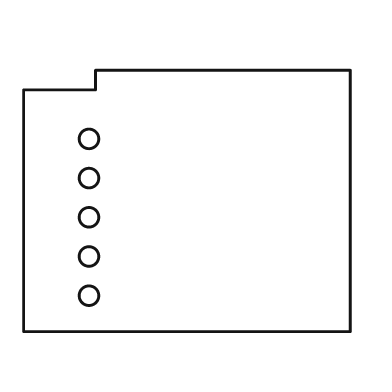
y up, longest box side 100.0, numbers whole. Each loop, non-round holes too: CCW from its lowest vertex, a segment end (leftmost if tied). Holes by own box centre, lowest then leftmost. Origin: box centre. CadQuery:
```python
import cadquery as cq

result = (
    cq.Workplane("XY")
    .moveTo(-50.0, -40.0)
    .lineTo(50.0, -40.0)
    .lineTo(50.0, 40.0)
    .lineTo(-28.0, 40.0)
    .lineTo(-28.0, 34.0)
    .lineTo(-50.0, 34.0)
    .close()
    .moveTo(-30.0, -29.0)
    .circle(3.0)
    .moveTo(-30.0, -17.0)
    .circle(3.0)
    .moveTo(-30.0, -5.0)
    .circle(3.0)
    .moveTo(-30.0, 7.0)
    .circle(3.0)
    .moveTo(-30.0, 19.0)
    .circle(3.0)
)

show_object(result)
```